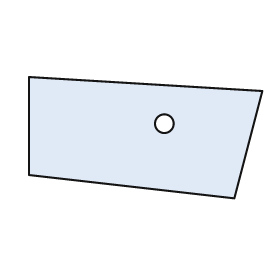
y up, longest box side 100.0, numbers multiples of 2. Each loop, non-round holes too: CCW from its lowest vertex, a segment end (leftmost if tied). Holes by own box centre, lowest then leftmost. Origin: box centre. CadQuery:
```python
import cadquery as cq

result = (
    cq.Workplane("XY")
    .moveTo(38.0, -26.0)
    .lineTo(50.0, 20.0)
    .lineTo(-50.0, 26.0)
    .lineTo(-50.0, -16.0)
    .close()
    .moveTo(8.0, 6.0)
    .circle(4.0)
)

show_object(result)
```